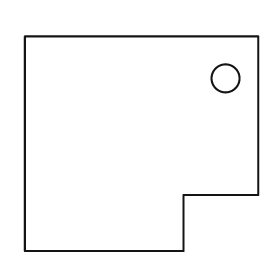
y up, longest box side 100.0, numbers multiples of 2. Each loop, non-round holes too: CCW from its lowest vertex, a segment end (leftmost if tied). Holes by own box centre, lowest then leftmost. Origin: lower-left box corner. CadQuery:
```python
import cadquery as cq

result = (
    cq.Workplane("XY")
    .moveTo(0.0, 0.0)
    .lineTo(68.0, 0.0)
    .lineTo(68.0, 24.0)
    .lineTo(100.0, 24.0)
    .lineTo(100.0, 92.0)
    .lineTo(0.0, 92.0)
    .close()
    .moveTo(86.0, 74.0)
    .circle(6.0)
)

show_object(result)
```